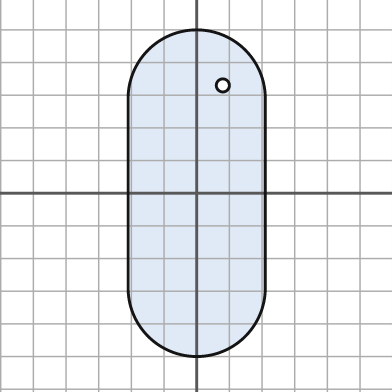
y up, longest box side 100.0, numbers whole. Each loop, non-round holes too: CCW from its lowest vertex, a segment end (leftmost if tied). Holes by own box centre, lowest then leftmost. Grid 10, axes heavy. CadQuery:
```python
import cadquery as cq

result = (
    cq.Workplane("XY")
    .moveTo(-21.0, -29.0)
    .threePointArc((0.0, -50.0), (21.0, -29.0))
    .lineTo(21.0, 29.0)
    .threePointArc((0.0, 50.0), (-21.0, 29.0))
    .close()
    .moveTo(8.0, 33.0)
    .circle(2.0)
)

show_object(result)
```